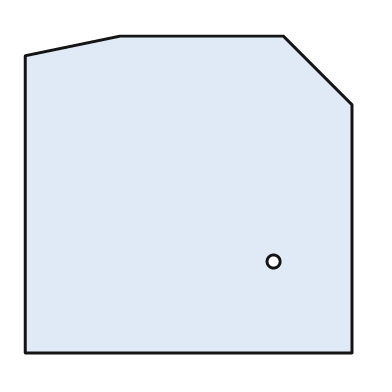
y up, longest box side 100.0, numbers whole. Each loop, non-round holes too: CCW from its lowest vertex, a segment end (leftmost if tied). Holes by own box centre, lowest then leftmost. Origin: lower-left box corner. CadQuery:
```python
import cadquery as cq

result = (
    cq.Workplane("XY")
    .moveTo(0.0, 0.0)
    .lineTo(100.0, 0.0)
    .lineTo(100.0, 76.0)
    .lineTo(79.0, 97.0)
    .lineTo(29.0, 97.0)
    .lineTo(0.0, 91.0)
    .close()
    .moveTo(76.0, 28.0)
    .circle(2.0)
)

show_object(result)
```